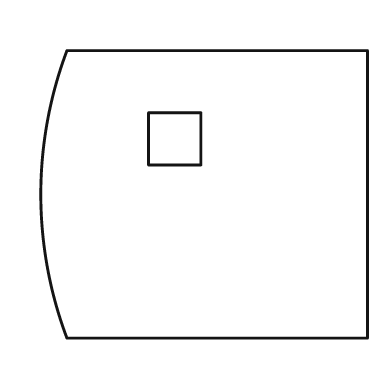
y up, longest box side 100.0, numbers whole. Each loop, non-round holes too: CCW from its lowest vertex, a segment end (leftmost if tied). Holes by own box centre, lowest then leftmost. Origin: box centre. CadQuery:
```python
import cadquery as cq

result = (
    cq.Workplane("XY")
    .moveTo(-42.0, -44.0)
    .lineTo(50.0, -44.0)
    .lineTo(50.0, 44.0)
    .lineTo(-42.0, 44.0)
    .threePointArc((-50.0, 0.0), (-42.0, -44.0))
    .close()
    .moveTo(-17.0, 9.0)
    .lineTo(-1.0, 9.0)
    .lineTo(-1.0, 25.0)
    .lineTo(-17.0, 25.0)
    .close()
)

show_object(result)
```